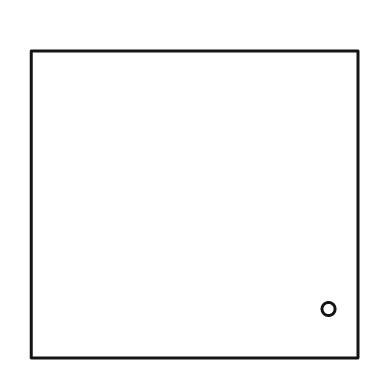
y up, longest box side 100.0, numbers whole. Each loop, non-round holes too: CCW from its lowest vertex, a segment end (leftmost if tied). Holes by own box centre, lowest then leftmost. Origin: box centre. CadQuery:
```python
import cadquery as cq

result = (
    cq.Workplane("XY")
    .moveTo(-50.0, -47.0)
    .lineTo(50.0, -47.0)
    .lineTo(50.0, 47.0)
    .lineTo(-50.0, 47.0)
    .close()
    .moveTo(41.0, -32.0)
    .circle(2.0)
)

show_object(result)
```